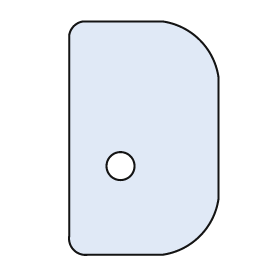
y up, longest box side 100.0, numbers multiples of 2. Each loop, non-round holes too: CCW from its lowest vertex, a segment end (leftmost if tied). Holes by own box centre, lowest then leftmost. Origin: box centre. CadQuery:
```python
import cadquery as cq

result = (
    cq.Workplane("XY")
    .moveTo(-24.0, -50.0)
    .lineTo(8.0, -50.0)
    .threePointArc((24.0, -42.0), (32.0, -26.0))
    .lineTo(32.0, 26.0)
    .threePointArc((24.0, 42.0), (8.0, 50.0))
    .lineTo(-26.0, 50.0)
    .threePointArc((-30.0, 48.0), (-32.0, 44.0))
    .lineTo(-32.0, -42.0)
    .threePointArc((-30.0, -48.0), (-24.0, -50.0))
    .close()
    .moveTo(-10.0, -12.0)
    .circle(6.0)
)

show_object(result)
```